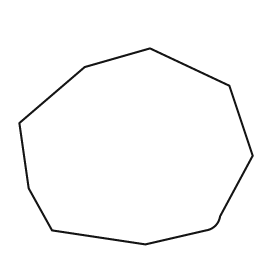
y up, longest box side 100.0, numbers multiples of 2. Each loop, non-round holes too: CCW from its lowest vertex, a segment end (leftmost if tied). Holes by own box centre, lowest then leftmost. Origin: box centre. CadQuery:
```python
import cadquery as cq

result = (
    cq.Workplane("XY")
    .moveTo(4.0, -42.0)
    .lineTo(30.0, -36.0)
    .threePointArc((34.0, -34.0), (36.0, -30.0))
    .lineTo(50.0, -4.0)
    .lineTo(40.0, 26.0)
    .lineTo(6.0, 42.0)
    .lineTo(-22.0, 34.0)
    .lineTo(-50.0, 10.0)
    .lineTo(-46.0, -18.0)
    .lineTo(-36.0, -36.0)
    .close()
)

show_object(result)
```